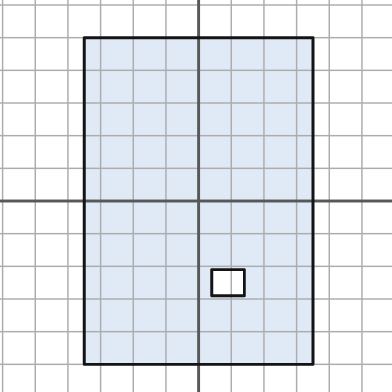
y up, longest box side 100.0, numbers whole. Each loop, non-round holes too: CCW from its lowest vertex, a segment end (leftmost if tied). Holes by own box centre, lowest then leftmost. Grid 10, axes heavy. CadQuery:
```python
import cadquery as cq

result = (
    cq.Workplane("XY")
    .moveTo(-35.0, -50.0)
    .lineTo(35.0, -50.0)
    .lineTo(35.0, 50.0)
    .lineTo(-35.0, 50.0)
    .close()
    .moveTo(4.0, -29.0)
    .lineTo(14.0, -29.0)
    .lineTo(14.0, -21.0)
    .lineTo(4.0, -21.0)
    .close()
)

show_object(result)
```